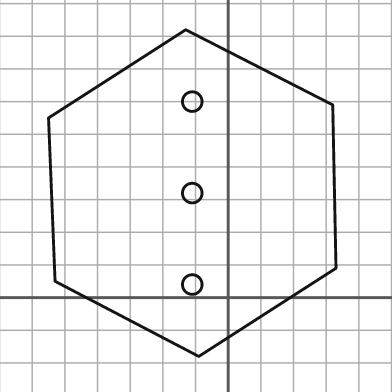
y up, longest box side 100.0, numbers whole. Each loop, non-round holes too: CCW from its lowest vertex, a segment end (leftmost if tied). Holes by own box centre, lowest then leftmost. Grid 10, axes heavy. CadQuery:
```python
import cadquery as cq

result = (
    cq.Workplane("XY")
    .moveTo(-9.0, -18.0)
    .lineTo(33.0, 9.0)
    .lineTo(32.0, 59.0)
    .lineTo(-13.0, 82.0)
    .lineTo(-55.0, 55.0)
    .lineTo(-53.0, 5.0)
    .close()
    .moveTo(-11.0, 4.0)
    .circle(3.0)
    .moveTo(-11.0, 32.0)
    .circle(3.0)
    .moveTo(-11.0, 60.0)
    .circle(3.0)
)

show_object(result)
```